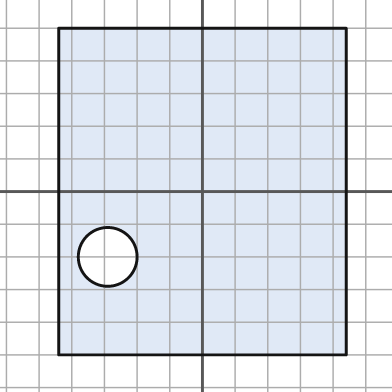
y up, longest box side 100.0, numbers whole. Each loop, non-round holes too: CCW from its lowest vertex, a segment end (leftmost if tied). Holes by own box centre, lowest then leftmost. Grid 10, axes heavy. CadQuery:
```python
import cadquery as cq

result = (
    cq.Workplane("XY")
    .moveTo(-44.0, -50.0)
    .lineTo(44.0, -50.0)
    .lineTo(44.0, 50.0)
    .lineTo(-44.0, 50.0)
    .close()
    .moveTo(-29.0, -20.0)
    .circle(9.0)
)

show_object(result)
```